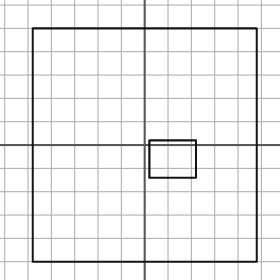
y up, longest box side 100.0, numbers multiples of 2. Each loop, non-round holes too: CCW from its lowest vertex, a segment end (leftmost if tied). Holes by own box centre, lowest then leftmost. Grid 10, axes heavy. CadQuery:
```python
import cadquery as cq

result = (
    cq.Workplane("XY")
    .moveTo(-48.0, -50.0)
    .lineTo(48.0, -50.0)
    .lineTo(48.0, 50.0)
    .lineTo(-48.0, 50.0)
    .close()
    .moveTo(2.0, -14.0)
    .lineTo(22.0, -14.0)
    .lineTo(22.0, 2.0)
    .lineTo(2.0, 2.0)
    .close()
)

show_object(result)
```